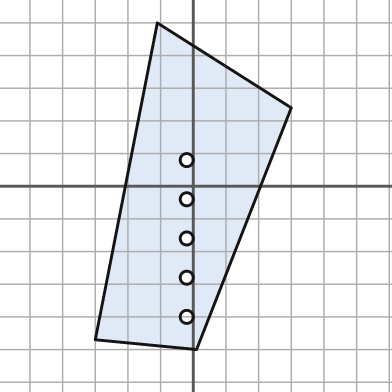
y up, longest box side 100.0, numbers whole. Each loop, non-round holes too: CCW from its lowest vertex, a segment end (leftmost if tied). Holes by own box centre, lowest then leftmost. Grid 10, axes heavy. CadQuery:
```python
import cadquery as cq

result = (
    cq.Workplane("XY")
    .moveTo(1.0, -50.0)
    .lineTo(30.0, 24.0)
    .lineTo(-11.0, 50.0)
    .lineTo(-30.0, -47.0)
    .close()
    .moveTo(-2.0, -40.0)
    .circle(2.0)
    .moveTo(-2.0, -28.0)
    .circle(2.0)
    .moveTo(-2.0, -16.0)
    .circle(2.0)
    .moveTo(-2.0, -4.0)
    .circle(2.0)
    .moveTo(-2.0, 8.0)
    .circle(2.0)
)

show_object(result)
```